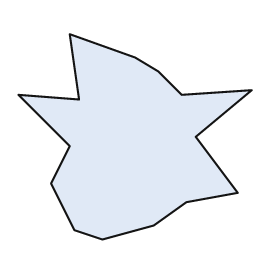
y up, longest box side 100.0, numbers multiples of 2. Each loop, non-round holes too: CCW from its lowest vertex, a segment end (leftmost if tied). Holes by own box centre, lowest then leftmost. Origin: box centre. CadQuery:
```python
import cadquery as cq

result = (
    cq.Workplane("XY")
    .moveTo(-14.0, -44.0)
    .lineTo(8.0, -38.0)
    .lineTo(22.0, -28.0)
    .lineTo(44.0, -24.0)
    .lineTo(26.0, 0.0)
    .lineTo(50.0, 20.0)
    .lineTo(20.0, 18.0)
    .lineTo(10.0, 28.0)
    .lineTo(0.0, 34.0)
    .lineTo(-28.0, 44.0)
    .lineTo(-24.0, 16.0)
    .lineTo(-50.0, 18.0)
    .lineTo(-28.0, -4.0)
    .lineTo(-36.0, -20.0)
    .lineTo(-26.0, -40.0)
    .close()
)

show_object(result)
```